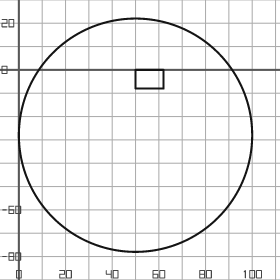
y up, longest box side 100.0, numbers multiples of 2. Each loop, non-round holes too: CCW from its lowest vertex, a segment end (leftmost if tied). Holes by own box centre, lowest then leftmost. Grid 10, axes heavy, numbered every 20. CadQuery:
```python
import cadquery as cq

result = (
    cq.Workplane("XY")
    .moveTo(50.0, -28.0)
    .circle(50.0)
    .moveTo(50.0, -8.0)
    .lineTo(62.0, -8.0)
    .lineTo(62.0, 0.0)
    .lineTo(50.0, 0.0)
    .close()
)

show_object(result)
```